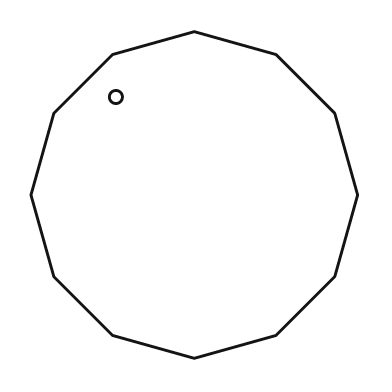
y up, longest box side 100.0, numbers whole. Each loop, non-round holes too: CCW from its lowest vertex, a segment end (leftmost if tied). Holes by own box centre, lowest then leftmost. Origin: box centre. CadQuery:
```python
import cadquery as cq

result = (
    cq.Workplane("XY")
    .moveTo(0.0, -50.0)
    .lineTo(25.0, -43.0)
    .lineTo(43.0, -25.0)
    .lineTo(50.0, 0.0)
    .lineTo(43.0, 25.0)
    .lineTo(25.0, 43.0)
    .lineTo(0.0, 50.0)
    .lineTo(-25.0, 43.0)
    .lineTo(-43.0, 25.0)
    .lineTo(-50.0, 0.0)
    .lineTo(-43.0, -25.0)
    .lineTo(-25.0, -43.0)
    .close()
    .moveTo(-24.0, 30.0)
    .circle(2.0)
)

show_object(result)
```